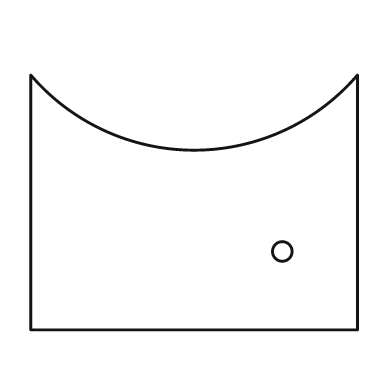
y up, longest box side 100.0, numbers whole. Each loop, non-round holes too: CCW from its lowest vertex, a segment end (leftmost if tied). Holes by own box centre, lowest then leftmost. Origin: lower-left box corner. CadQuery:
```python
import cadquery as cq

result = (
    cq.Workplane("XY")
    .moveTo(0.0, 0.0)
    .lineTo(100.0, 0.0)
    .lineTo(100.0, 78.0)
    .threePointArc((50.0, 55.0), (0.0, 78.0))
    .close()
    .moveTo(77.0, 24.0)
    .circle(3.0)
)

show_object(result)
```